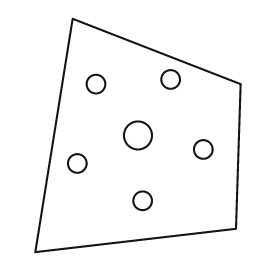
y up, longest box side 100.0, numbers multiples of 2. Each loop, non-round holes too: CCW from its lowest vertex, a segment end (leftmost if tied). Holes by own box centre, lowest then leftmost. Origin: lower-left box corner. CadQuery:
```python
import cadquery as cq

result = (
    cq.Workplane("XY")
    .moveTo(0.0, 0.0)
    .lineTo(86.0, 10.0)
    .lineTo(88.0, 72.0)
    .lineTo(16.0, 100.0)
    .close()
    .moveTo(46.0, 22.0)
    .circle(4.0)
    .moveTo(18.0, 38.0)
    .circle(4.0)
    .moveTo(72.0, 44.0)
    .circle(4.0)
    .moveTo(44.0, 50.0)
    .circle(6.0)
    .moveTo(26.0, 72.0)
    .circle(4.0)
    .moveTo(58.0, 74.0)
    .circle(4.0)
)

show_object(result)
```